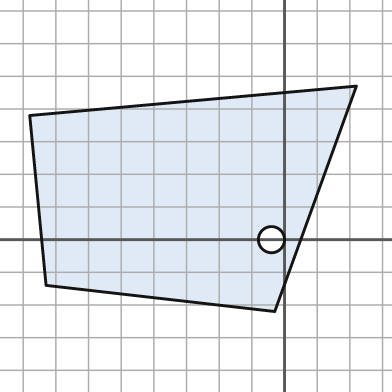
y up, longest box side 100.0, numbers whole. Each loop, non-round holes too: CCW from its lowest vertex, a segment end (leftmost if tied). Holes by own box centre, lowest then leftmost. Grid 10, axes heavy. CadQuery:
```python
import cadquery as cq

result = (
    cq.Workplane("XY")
    .moveTo(-3.0, -22.0)
    .lineTo(22.0, 47.0)
    .lineTo(-78.0, 38.0)
    .lineTo(-73.0, -14.0)
    .close()
    .moveTo(-4.0, 0.0)
    .circle(4.0)
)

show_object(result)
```